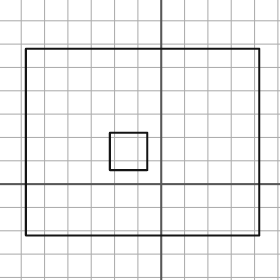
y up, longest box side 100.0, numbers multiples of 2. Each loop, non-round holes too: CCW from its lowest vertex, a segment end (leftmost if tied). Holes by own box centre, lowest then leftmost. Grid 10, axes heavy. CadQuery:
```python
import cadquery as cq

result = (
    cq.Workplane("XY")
    .moveTo(-58.0, -22.0)
    .lineTo(42.0, -22.0)
    .lineTo(42.0, 58.0)
    .lineTo(-58.0, 58.0)
    .close()
    .moveTo(-22.0, 6.0)
    .lineTo(-6.0, 6.0)
    .lineTo(-6.0, 22.0)
    .lineTo(-22.0, 22.0)
    .close()
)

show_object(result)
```